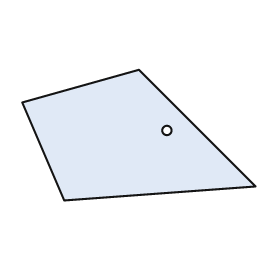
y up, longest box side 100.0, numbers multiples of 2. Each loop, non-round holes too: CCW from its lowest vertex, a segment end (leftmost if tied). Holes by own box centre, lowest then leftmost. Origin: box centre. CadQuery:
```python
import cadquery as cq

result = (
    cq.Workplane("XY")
    .moveTo(-32.0, -28.0)
    .lineTo(50.0, -22.0)
    .lineTo(0.0, 28.0)
    .lineTo(-50.0, 14.0)
    .close()
    .moveTo(12.0, 2.0)
    .circle(2.0)
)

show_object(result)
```